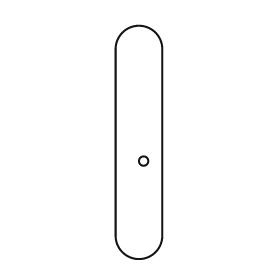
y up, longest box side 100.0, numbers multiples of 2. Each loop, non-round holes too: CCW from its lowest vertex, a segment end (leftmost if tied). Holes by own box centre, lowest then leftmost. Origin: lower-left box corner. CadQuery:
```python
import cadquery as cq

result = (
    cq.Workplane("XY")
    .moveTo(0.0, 10.0)
    .threePointArc((10.0, 0.0), (20.0, 10.0))
    .lineTo(20.0, 90.0)
    .threePointArc((10.0, 100.0), (0.0, 90.0))
    .close()
    .moveTo(12.0, 42.0)
    .circle(2.0)
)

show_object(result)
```